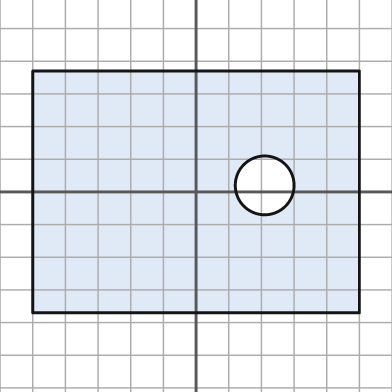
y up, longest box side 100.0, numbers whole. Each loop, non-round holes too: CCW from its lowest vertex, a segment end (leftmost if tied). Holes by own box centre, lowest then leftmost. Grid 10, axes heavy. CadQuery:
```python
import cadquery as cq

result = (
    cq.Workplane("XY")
    .moveTo(-50.0, -37.0)
    .lineTo(50.0, -37.0)
    .lineTo(50.0, 37.0)
    .lineTo(-50.0, 37.0)
    .close()
    .moveTo(21.0, 2.0)
    .circle(9.0)
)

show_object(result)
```